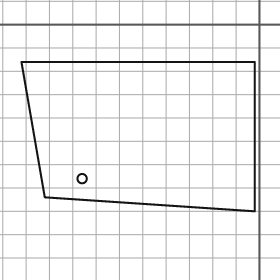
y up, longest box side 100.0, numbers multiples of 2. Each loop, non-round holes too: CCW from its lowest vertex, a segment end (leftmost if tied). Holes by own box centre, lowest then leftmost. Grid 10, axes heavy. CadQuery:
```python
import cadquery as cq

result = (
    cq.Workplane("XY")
    .moveTo(-2.0, -80.0)
    .lineTo(-2.0, -16.0)
    .lineTo(-102.0, -16.0)
    .lineTo(-92.0, -74.0)
    .close()
    .moveTo(-76.0, -66.0)
    .circle(2.0)
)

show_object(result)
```